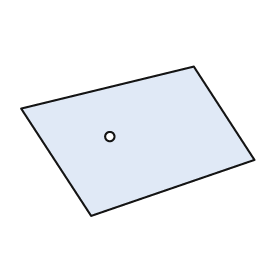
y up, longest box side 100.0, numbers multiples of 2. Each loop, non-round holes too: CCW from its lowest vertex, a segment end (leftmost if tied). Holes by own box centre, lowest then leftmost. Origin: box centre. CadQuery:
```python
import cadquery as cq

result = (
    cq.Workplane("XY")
    .moveTo(-20.0, -32.0)
    .lineTo(50.0, -8.0)
    .lineTo(24.0, 32.0)
    .lineTo(-50.0, 14.0)
    .close()
    .moveTo(-12.0, 2.0)
    .circle(2.0)
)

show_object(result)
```